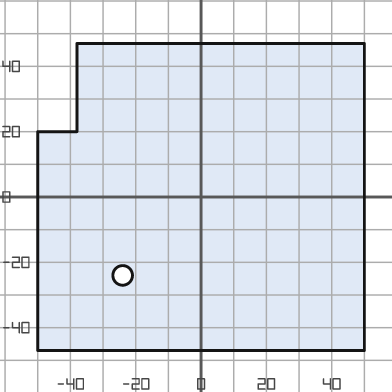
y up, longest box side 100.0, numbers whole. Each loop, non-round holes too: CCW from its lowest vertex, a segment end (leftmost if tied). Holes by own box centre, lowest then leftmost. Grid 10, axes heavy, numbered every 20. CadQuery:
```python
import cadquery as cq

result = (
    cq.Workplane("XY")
    .moveTo(-50.0, -47.0)
    .lineTo(50.0, -47.0)
    .lineTo(50.0, 47.0)
    .lineTo(-38.0, 47.0)
    .lineTo(-38.0, 20.0)
    .lineTo(-50.0, 20.0)
    .close()
    .moveTo(-24.0, -24.0)
    .circle(3.0)
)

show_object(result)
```